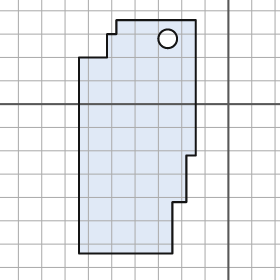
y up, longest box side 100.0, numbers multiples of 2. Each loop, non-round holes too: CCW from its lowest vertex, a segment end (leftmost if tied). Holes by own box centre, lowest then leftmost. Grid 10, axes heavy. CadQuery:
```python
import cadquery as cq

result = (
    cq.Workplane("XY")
    .moveTo(-64.0, -64.0)
    .lineTo(-24.0, -64.0)
    .lineTo(-24.0, -42.0)
    .lineTo(-18.0, -42.0)
    .lineTo(-18.0, -22.0)
    .lineTo(-14.0, -22.0)
    .lineTo(-14.0, 36.0)
    .lineTo(-48.0, 36.0)
    .lineTo(-48.0, 30.0)
    .lineTo(-52.0, 30.0)
    .lineTo(-52.0, 20.0)
    .lineTo(-64.0, 20.0)
    .close()
    .moveTo(-26.0, 28.0)
    .circle(4.0)
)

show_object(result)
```